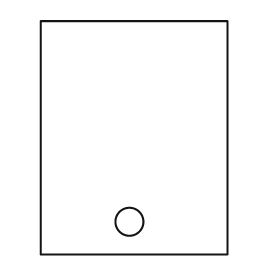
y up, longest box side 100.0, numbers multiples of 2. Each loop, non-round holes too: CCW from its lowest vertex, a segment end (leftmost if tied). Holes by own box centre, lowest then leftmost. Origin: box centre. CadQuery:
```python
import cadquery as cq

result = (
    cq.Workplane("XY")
    .moveTo(-40.0, -50.0)
    .lineTo(40.0, -50.0)
    .lineTo(40.0, 50.0)
    .lineTo(-40.0, 50.0)
    .close()
    .moveTo(-2.0, -36.0)
    .circle(6.0)
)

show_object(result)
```